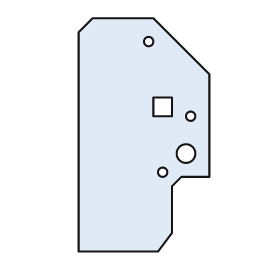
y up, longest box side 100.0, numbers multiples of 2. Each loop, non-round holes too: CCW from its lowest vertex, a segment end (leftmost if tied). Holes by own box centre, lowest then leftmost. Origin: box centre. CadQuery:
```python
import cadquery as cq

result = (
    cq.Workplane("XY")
    .moveTo(-28.0, -50.0)
    .lineTo(6.0, -50.0)
    .lineTo(12.0, -42.0)
    .lineTo(12.0, -22.0)
    .lineTo(16.0, -18.0)
    .lineTo(28.0, -18.0)
    .lineTo(28.0, 26.0)
    .lineTo(4.0, 50.0)
    .lineTo(-22.0, 50.0)
    .lineTo(-28.0, 44.0)
    .close()
    .moveTo(8.0, -16.0)
    .circle(2.0)
    .moveTo(18.0, -8.0)
    .circle(4.0)
    .moveTo(20.0, 8.0)
    .circle(2.0)
    .moveTo(4.0, 8.0)
    .lineTo(12.0, 8.0)
    .lineTo(12.0, 16.0)
    .lineTo(4.0, 16.0)
    .close()
    .moveTo(2.0, 40.0)
    .circle(2.0)
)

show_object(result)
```